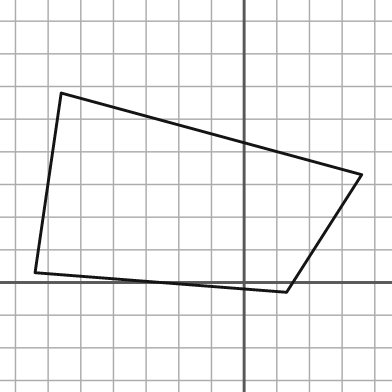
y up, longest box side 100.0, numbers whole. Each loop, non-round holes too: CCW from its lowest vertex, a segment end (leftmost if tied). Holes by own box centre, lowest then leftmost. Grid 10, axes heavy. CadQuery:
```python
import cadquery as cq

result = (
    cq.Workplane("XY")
    .moveTo(13.0, -3.0)
    .lineTo(36.0, 33.0)
    .lineTo(-56.0, 58.0)
    .lineTo(-64.0, 3.0)
    .close()
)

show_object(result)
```